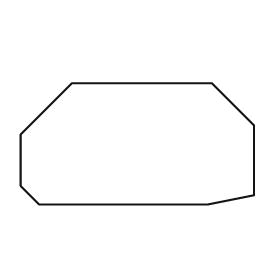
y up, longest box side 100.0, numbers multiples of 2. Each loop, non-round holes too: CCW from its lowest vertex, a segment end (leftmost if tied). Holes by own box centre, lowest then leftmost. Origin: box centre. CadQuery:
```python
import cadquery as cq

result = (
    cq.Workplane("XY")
    .moveTo(-42.0, -26.0)
    .lineTo(30.0, -26.0)
    .lineTo(50.0, -22.0)
    .lineTo(50.0, 8.0)
    .lineTo(32.0, 26.0)
    .lineTo(-28.0, 26.0)
    .lineTo(-50.0, 4.0)
    .lineTo(-50.0, -18.0)
    .close()
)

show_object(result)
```